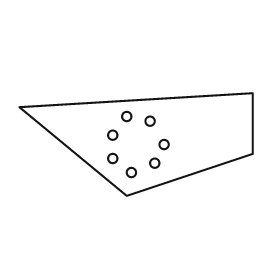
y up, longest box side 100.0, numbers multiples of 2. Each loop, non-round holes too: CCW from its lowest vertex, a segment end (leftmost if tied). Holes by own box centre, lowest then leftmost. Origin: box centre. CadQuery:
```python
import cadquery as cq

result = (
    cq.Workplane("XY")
    .moveTo(-4.0, -22.0)
    .lineTo(50.0, -4.0)
    .lineTo(50.0, 22.0)
    .lineTo(-50.0, 16.0)
    .close()
    .moveTo(-2.0, -12.0)
    .circle(2.0)
    .moveTo(8.0, -8.0)
    .circle(2.0)
    .moveTo(-10.0, -6.0)
    .circle(2.0)
    .moveTo(12.0, 0.0)
    .circle(2.0)
    .moveTo(-10.0, 4.0)
    .circle(2.0)
    .moveTo(6.0, 10.0)
    .circle(2.0)
    .moveTo(-4.0, 12.0)
    .circle(2.0)
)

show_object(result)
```